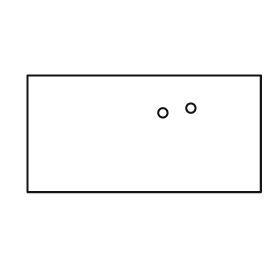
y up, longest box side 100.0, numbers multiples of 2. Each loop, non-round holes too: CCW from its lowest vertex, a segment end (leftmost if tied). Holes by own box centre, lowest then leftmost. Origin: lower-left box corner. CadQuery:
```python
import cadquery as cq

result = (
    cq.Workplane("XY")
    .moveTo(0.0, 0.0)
    .lineTo(100.0, 0.0)
    .lineTo(100.0, 50.0)
    .lineTo(0.0, 50.0)
    .close()
    .moveTo(58.0, 34.0)
    .circle(2.0)
    .moveTo(70.0, 36.0)
    .circle(2.0)
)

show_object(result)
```